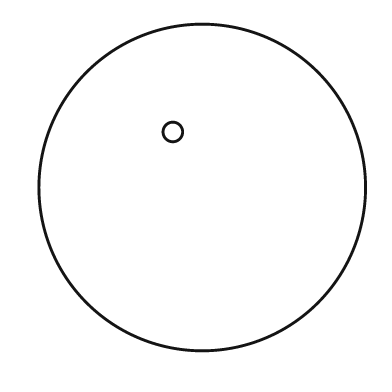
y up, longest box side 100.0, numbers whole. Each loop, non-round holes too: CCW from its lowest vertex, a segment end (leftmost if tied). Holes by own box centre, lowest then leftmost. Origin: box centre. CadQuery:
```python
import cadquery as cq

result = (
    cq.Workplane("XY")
    .moveTo(0.0, 0.0)
    .circle(50.0)
    .moveTo(-9.0, 17.0)
    .circle(3.0)
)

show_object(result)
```